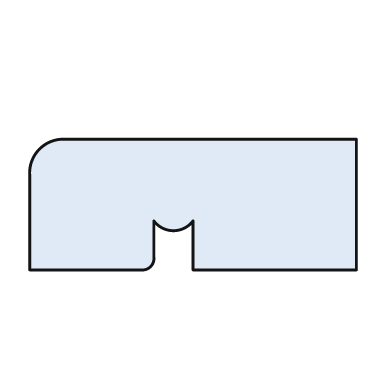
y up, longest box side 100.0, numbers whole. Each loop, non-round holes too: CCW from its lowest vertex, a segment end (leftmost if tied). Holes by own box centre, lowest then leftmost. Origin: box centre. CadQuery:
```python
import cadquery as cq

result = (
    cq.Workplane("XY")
    .moveTo(-50.0, -20.0)
    .lineTo(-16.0, -20.0)
    .threePointArc((-13.0, -19.0), (-12.0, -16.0))
    .lineTo(-12.0, -5.0)
    .threePointArc((-6.0, -8.0), (0.0, -5.0))
    .lineTo(0.0, -20.0)
    .lineTo(50.0, -20.0)
    .lineTo(50.0, 20.0)
    .lineTo(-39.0, 20.0)
    .threePointArc((-47.0, 17.0), (-50.0, 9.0))
    .close()
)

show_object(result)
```